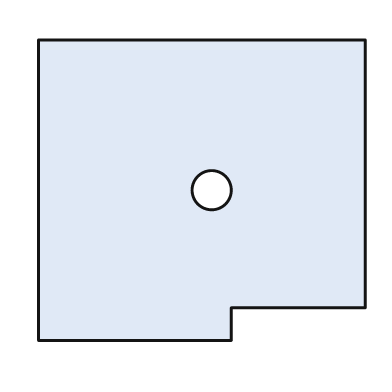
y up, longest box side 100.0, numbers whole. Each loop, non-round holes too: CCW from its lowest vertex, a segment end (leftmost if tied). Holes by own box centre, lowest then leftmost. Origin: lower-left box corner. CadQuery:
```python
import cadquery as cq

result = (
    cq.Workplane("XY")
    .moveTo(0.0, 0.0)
    .lineTo(59.0, 0.0)
    .lineTo(59.0, 10.0)
    .lineTo(100.0, 10.0)
    .lineTo(100.0, 92.0)
    .lineTo(0.0, 92.0)
    .close()
    .moveTo(53.0, 46.0)
    .circle(6.0)
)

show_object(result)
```